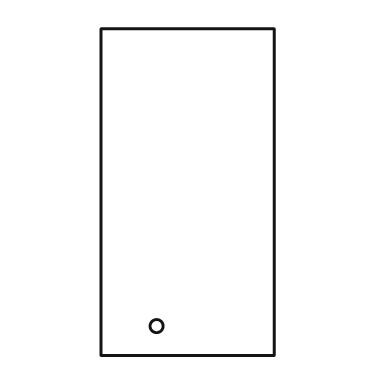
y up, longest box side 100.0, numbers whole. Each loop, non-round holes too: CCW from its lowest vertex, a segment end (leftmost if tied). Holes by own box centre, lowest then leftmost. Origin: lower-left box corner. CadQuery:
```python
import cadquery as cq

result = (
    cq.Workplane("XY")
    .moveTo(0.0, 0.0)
    .lineTo(53.0, 0.0)
    .lineTo(53.0, 100.0)
    .lineTo(0.0, 100.0)
    .close()
    .moveTo(17.0, 9.0)
    .circle(2.0)
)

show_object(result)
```